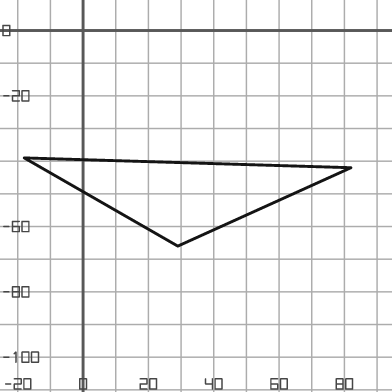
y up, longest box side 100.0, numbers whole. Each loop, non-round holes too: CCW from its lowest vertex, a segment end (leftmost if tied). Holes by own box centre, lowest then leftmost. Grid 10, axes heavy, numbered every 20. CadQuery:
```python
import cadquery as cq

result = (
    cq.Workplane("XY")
    .moveTo(29.0, -66.0)
    .lineTo(82.0, -42.0)
    .lineTo(-18.0, -39.0)
    .close()
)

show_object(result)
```